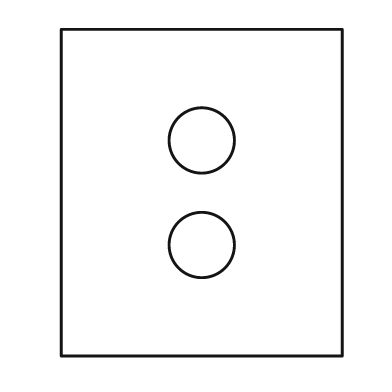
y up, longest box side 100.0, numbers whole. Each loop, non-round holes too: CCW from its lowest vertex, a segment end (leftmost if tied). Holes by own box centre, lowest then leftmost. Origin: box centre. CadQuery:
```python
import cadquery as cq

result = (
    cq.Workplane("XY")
    .moveTo(-43.0, -50.0)
    .lineTo(43.0, -50.0)
    .lineTo(43.0, 50.0)
    .lineTo(-43.0, 50.0)
    .close()
    .moveTo(0.0, -16.0)
    .circle(10.0)
    .moveTo(0.0, 16.0)
    .circle(10.0)
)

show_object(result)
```